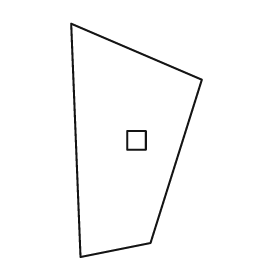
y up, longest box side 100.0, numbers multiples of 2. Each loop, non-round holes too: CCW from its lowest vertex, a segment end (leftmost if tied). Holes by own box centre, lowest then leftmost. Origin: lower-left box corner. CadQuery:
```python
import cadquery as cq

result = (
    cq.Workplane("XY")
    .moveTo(4.0, 0.0)
    .lineTo(34.0, 6.0)
    .lineTo(56.0, 76.0)
    .lineTo(0.0, 100.0)
    .close()
    .moveTo(24.0, 46.0)
    .lineTo(32.0, 46.0)
    .lineTo(32.0, 54.0)
    .lineTo(24.0, 54.0)
    .close()
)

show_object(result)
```